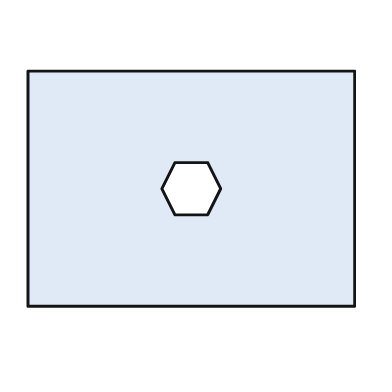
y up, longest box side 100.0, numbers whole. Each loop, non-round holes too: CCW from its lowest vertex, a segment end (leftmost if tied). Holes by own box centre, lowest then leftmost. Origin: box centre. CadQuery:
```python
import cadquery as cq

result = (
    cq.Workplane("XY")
    .moveTo(-50.0, -36.0)
    .lineTo(50.0, -36.0)
    .lineTo(50.0, 36.0)
    .lineTo(-50.0, 36.0)
    .close()
    .moveTo(-5.0, -8.0)
    .lineTo(5.0, -8.0)
    .lineTo(9.0, 0.0)
    .lineTo(5.0, 8.0)
    .lineTo(-5.0, 8.0)
    .lineTo(-9.0, 0.0)
    .close()
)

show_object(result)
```